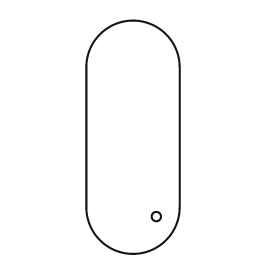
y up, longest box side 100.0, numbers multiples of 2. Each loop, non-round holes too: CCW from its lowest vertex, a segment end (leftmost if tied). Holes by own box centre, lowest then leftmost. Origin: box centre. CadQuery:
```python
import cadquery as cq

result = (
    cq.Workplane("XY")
    .moveTo(-20.0, -30.0)
    .threePointArc((0.0, -50.0), (20.0, -30.0))
    .lineTo(20.0, 30.0)
    .threePointArc((0.0, 50.0), (-20.0, 30.0))
    .close()
    .moveTo(10.0, -34.0)
    .circle(2.0)
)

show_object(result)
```